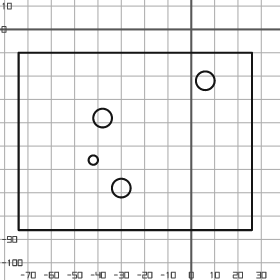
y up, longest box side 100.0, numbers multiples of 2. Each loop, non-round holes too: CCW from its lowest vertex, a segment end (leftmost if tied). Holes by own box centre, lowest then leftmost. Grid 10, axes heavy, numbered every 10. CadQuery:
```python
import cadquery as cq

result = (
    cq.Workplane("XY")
    .moveTo(-74.0, -86.0)
    .lineTo(26.0, -86.0)
    .lineTo(26.0, -10.0)
    .lineTo(-74.0, -10.0)
    .close()
    .moveTo(-30.0, -68.0)
    .circle(4.0)
    .moveTo(-42.0, -56.0)
    .circle(2.0)
    .moveTo(-38.0, -38.0)
    .circle(4.0)
    .moveTo(6.0, -22.0)
    .circle(4.0)
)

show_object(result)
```